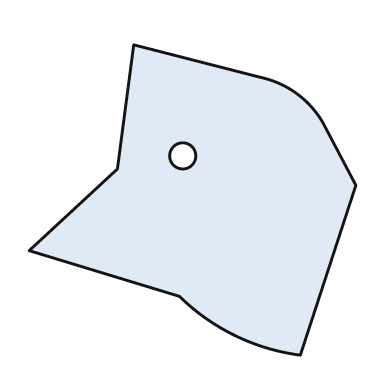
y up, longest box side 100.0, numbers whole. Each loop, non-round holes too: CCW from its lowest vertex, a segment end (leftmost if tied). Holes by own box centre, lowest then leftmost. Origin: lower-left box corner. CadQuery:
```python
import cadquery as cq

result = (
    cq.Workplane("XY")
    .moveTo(83.0, 0.0)
    .lineTo(100.0, 52.0)
    .lineTo(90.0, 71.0)
    .threePointArc((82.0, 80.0), (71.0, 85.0))
    .lineTo(32.0, 95.0)
    .lineTo(27.0, 57.0)
    .lineTo(0.0, 32.0)
    .lineTo(46.0, 18.0)
    .threePointArc((63.0, 6.0), (83.0, 0.0))
    .close()
    .moveTo(47.0, 61.0)
    .circle(4.0)
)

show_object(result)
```